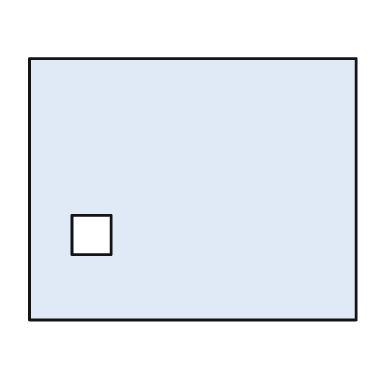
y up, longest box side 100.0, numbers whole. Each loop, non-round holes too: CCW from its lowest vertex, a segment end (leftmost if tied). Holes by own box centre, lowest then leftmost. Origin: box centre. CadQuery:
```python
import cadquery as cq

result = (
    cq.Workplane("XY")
    .moveTo(-50.0, -40.0)
    .lineTo(50.0, -40.0)
    .lineTo(50.0, 40.0)
    .lineTo(-50.0, 40.0)
    .close()
    .moveTo(-37.0, -20.0)
    .lineTo(-25.0, -20.0)
    .lineTo(-25.0, -8.0)
    .lineTo(-37.0, -8.0)
    .close()
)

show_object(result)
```